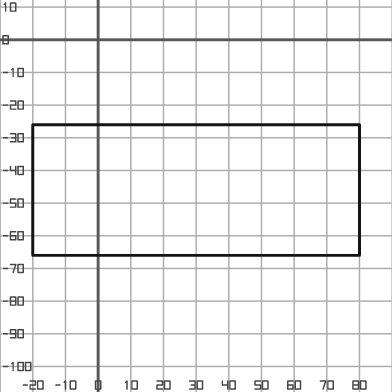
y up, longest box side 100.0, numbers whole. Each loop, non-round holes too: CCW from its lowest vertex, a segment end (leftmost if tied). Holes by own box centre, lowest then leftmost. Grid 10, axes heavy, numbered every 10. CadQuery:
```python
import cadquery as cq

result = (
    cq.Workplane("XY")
    .moveTo(-20.0, -66.0)
    .lineTo(80.0, -66.0)
    .lineTo(80.0, -26.0)
    .lineTo(-20.0, -26.0)
    .close()
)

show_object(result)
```